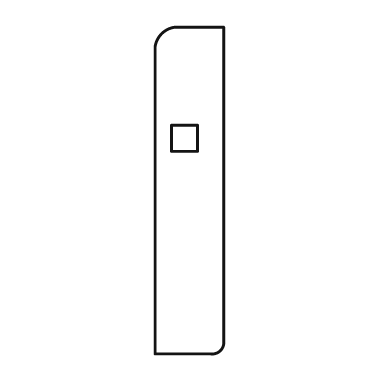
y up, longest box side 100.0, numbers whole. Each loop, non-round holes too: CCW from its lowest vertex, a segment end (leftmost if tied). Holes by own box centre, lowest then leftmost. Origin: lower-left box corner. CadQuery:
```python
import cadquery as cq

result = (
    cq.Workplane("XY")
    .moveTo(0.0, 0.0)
    .lineTo(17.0, 0.0)
    .threePointArc((20.0, 1.0), (21.0, 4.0))
    .lineTo(21.0, 100.0)
    .lineTo(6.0, 100.0)
    .threePointArc((2.0, 98.0), (0.0, 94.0))
    .close()
    .moveTo(5.0, 62.0)
    .lineTo(13.0, 62.0)
    .lineTo(13.0, 70.0)
    .lineTo(5.0, 70.0)
    .close()
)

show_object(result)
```